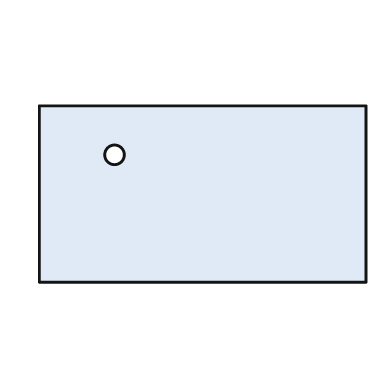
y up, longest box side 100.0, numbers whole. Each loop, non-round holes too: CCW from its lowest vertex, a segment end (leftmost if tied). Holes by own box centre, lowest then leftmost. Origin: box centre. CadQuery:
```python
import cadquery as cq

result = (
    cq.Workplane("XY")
    .moveTo(-50.0, -27.0)
    .lineTo(50.0, -27.0)
    .lineTo(50.0, 27.0)
    .lineTo(-50.0, 27.0)
    .close()
    .moveTo(-27.0, 12.0)
    .circle(3.0)
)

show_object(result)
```